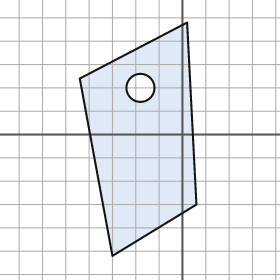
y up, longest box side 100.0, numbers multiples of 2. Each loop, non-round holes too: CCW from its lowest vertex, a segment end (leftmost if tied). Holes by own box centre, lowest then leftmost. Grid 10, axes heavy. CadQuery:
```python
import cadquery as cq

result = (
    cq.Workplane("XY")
    .moveTo(-30.0, -52.0)
    .lineTo(6.0, -30.0)
    .lineTo(2.0, 48.0)
    .lineTo(-44.0, 24.0)
    .close()
    .moveTo(-18.0, 20.0)
    .circle(6.0)
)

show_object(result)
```